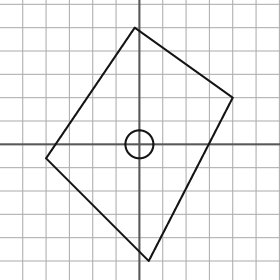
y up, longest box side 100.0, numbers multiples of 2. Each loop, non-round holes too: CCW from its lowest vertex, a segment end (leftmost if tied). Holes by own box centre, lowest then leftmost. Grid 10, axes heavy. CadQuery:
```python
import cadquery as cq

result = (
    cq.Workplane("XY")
    .moveTo(4.0, -50.0)
    .lineTo(40.0, 20.0)
    .lineTo(-2.0, 50.0)
    .lineTo(-40.0, -6.0)
    .close()
    .moveTo(0.0, 0.0)
    .circle(6.0)
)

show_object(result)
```